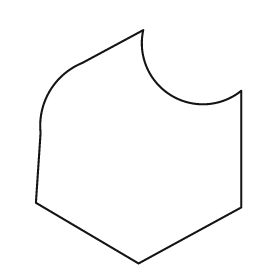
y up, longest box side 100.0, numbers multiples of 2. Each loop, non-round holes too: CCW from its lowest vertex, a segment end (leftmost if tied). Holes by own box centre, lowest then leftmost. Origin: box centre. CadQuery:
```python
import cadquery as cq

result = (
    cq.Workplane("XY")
    .moveTo(0.0, -50.0)
    .lineTo(44.0, -26.0)
    .lineTo(44.0, 24.0)
    .threePointArc((14.0, 22.0), (2.0, 50.0))
    .lineTo(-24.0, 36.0)
    .threePointArc((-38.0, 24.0), (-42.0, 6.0))
    .lineTo(-44.0, -24.0)
    .close()
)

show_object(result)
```